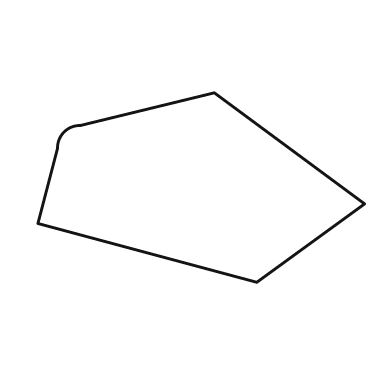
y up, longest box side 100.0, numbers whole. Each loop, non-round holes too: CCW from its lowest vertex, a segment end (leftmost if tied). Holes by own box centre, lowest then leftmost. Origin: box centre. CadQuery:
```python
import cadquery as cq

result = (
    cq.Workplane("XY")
    .moveTo(17.0, -29.0)
    .lineTo(50.0, -5.0)
    .lineTo(4.0, 29.0)
    .lineTo(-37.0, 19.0)
    .threePointArc((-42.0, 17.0), (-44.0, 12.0))
    .lineTo(-50.0, -11.0)
    .close()
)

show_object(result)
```